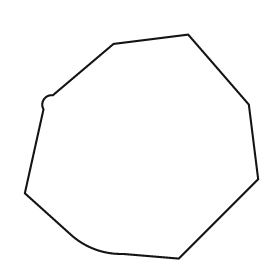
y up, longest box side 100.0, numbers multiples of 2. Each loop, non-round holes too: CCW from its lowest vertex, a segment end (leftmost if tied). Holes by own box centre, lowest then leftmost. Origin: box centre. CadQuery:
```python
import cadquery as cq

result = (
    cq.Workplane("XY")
    .moveTo(16.0, -48.0)
    .lineTo(50.0, -14.0)
    .lineTo(46.0, 18.0)
    .lineTo(20.0, 48.0)
    .lineTo(-12.0, 44.0)
    .lineTo(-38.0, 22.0)
    .threePointArc((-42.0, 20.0), (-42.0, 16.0))
    .lineTo(-50.0, -20.0)
    .lineTo(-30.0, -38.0)
    .threePointArc((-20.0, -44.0), (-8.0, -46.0))
    .close()
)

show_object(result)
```